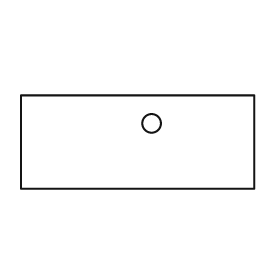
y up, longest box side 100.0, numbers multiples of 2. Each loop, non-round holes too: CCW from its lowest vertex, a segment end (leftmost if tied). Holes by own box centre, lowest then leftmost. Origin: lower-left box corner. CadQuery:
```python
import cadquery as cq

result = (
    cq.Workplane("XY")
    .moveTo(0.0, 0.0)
    .lineTo(100.0, 0.0)
    .lineTo(100.0, 40.0)
    .lineTo(0.0, 40.0)
    .close()
    .moveTo(56.0, 28.0)
    .circle(4.0)
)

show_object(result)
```